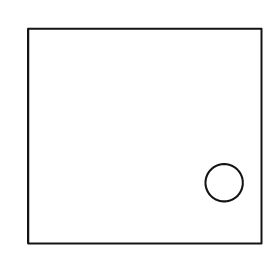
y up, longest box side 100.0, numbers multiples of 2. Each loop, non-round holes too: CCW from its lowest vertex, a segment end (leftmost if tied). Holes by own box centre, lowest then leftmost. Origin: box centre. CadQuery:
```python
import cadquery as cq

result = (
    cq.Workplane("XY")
    .moveTo(-50.0, -46.0)
    .lineTo(50.0, -46.0)
    .lineTo(50.0, 46.0)
    .lineTo(-50.0, 46.0)
    .close()
    .moveTo(34.0, -20.0)
    .circle(8.0)
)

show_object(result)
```